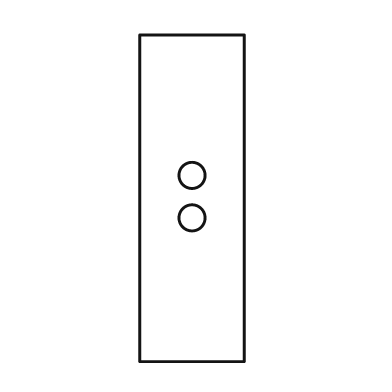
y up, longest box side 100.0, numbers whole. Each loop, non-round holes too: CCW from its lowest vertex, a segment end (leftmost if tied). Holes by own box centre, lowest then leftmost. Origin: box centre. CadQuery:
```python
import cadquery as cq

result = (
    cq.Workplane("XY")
    .moveTo(-16.0, -50.0)
    .lineTo(16.0, -50.0)
    .lineTo(16.0, 50.0)
    .lineTo(-16.0, 50.0)
    .close()
    .moveTo(0.0, -6.0)
    .circle(4.0)
    .moveTo(0.0, 7.0)
    .circle(4.0)
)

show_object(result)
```